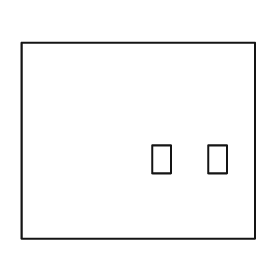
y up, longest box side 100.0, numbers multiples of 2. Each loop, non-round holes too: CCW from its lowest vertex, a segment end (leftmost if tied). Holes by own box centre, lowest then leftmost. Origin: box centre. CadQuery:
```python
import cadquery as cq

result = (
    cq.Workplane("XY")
    .moveTo(-50.0, -42.0)
    .lineTo(50.0, -42.0)
    .lineTo(50.0, 42.0)
    .lineTo(-50.0, 42.0)
    .close()
    .moveTo(6.0, -14.0)
    .lineTo(14.0, -14.0)
    .lineTo(14.0, -2.0)
    .lineTo(6.0, -2.0)
    .close()
    .moveTo(30.0, -14.0)
    .lineTo(38.0, -14.0)
    .lineTo(38.0, -2.0)
    .lineTo(30.0, -2.0)
    .close()
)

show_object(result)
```